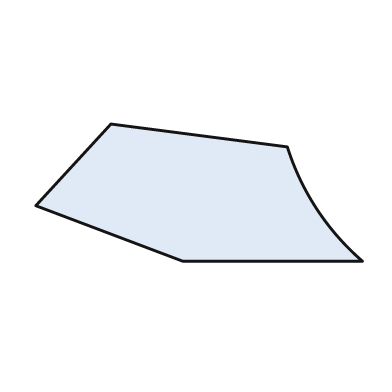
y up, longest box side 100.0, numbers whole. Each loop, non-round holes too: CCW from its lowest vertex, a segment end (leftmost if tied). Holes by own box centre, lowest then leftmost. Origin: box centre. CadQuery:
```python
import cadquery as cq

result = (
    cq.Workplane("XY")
    .moveTo(-5.0, -21.0)
    .lineTo(50.0, -21.0)
    .threePointArc((36.0, -5.0), (27.0, 14.0))
    .lineTo(-27.0, 21.0)
    .lineTo(-50.0, -4.0)
    .close()
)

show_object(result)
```